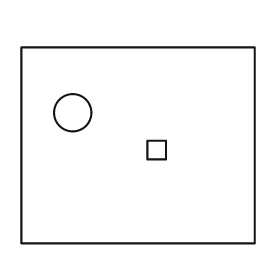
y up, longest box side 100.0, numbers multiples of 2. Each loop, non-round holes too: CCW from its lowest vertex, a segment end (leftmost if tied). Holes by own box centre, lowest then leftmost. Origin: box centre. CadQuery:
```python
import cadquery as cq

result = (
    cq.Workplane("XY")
    .moveTo(-50.0, -42.0)
    .lineTo(50.0, -42.0)
    .lineTo(50.0, 42.0)
    .lineTo(-50.0, 42.0)
    .close()
    .moveTo(4.0, -6.0)
    .lineTo(12.0, -6.0)
    .lineTo(12.0, 2.0)
    .lineTo(4.0, 2.0)
    .close()
    .moveTo(-28.0, 14.0)
    .circle(8.0)
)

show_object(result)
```